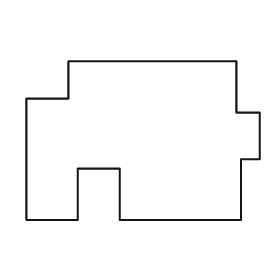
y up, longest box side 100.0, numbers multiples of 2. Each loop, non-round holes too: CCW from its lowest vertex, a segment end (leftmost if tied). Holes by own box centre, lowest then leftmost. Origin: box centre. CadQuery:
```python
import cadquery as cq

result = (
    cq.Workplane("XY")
    .moveTo(-50.0, -34.0)
    .lineTo(-28.0, -34.0)
    .lineTo(-28.0, -12.0)
    .lineTo(-10.0, -12.0)
    .lineTo(-10.0, -34.0)
    .lineTo(42.0, -34.0)
    .lineTo(42.0, -8.0)
    .lineTo(50.0, -8.0)
    .lineTo(50.0, 12.0)
    .lineTo(40.0, 12.0)
    .lineTo(40.0, 34.0)
    .lineTo(-32.0, 34.0)
    .lineTo(-32.0, 18.0)
    .lineTo(-50.0, 18.0)
    .close()
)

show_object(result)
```